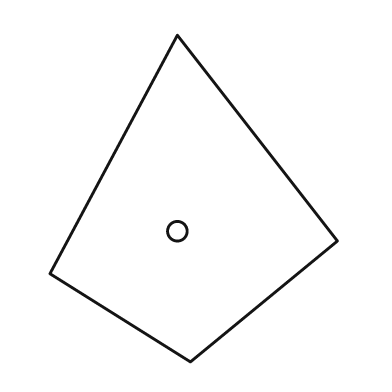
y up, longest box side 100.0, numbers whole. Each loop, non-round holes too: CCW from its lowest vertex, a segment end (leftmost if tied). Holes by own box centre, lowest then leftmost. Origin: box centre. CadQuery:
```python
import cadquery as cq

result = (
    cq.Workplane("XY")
    .moveTo(-1.0, -50.0)
    .lineTo(44.0, -13.0)
    .lineTo(-5.0, 50.0)
    .lineTo(-44.0, -23.0)
    .close()
    .moveTo(-5.0, -10.0)
    .circle(3.0)
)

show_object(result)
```